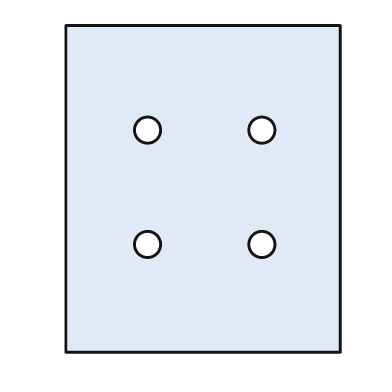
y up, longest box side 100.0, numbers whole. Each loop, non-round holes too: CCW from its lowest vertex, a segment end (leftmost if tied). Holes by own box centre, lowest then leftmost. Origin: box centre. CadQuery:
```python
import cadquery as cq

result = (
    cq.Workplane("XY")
    .moveTo(-42.0, -50.0)
    .lineTo(42.0, -50.0)
    .lineTo(42.0, 50.0)
    .lineTo(-42.0, 50.0)
    .close()
    .moveTo(-17.0, -17.0)
    .circle(4.0)
    .moveTo(18.0, -17.0)
    .circle(4.0)
    .moveTo(-17.0, 18.0)
    .circle(4.0)
    .moveTo(18.0, 18.0)
    .circle(4.0)
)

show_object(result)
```